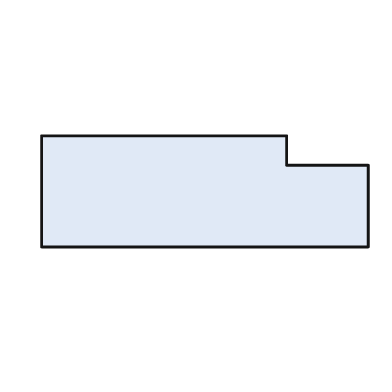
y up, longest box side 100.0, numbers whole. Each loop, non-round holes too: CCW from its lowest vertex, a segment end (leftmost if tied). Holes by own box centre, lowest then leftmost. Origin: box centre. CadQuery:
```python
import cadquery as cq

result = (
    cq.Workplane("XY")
    .moveTo(-50.0, -17.0)
    .lineTo(50.0, -17.0)
    .lineTo(50.0, 8.0)
    .lineTo(25.0, 8.0)
    .lineTo(25.0, 17.0)
    .lineTo(-50.0, 17.0)
    .close()
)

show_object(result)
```